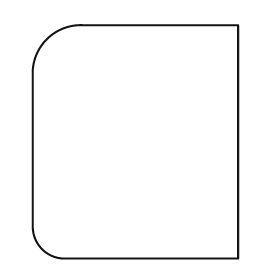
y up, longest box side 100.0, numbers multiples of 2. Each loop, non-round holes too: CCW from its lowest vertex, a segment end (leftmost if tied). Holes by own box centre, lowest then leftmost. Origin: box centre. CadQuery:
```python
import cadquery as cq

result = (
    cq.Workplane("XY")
    .moveTo(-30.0, -50.0)
    .lineTo(44.0, -50.0)
    .lineTo(44.0, 50.0)
    .lineTo(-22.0, 50.0)
    .threePointArc((-38.0, 44.0), (-44.0, 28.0))
    .lineTo(-44.0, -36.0)
    .threePointArc((-40.0, -46.0), (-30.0, -50.0))
    .close()
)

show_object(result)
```